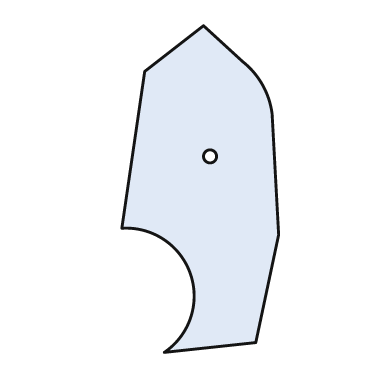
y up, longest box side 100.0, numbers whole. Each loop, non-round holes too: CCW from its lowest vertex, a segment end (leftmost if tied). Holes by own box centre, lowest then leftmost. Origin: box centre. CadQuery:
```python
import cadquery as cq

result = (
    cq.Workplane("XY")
    .moveTo(-11.0, -50.0)
    .lineTo(17.0, -47.0)
    .lineTo(24.0, -14.0)
    .lineTo(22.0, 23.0)
    .threePointArc((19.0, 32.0), (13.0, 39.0))
    .lineTo(1.0, 50.0)
    .lineTo(-17.0, 36.0)
    .lineTo(-24.0, -12.0)
    .threePointArc((-3.0, -26.0), (-11.0, -50.0))
    .close()
    .moveTo(3.0, 10.0)
    .circle(2.0)
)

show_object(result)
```